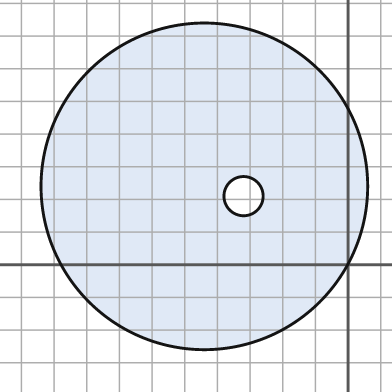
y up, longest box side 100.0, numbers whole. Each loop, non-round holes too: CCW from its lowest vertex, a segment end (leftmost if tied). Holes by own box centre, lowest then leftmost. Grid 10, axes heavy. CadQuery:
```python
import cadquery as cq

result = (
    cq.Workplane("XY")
    .moveTo(-44.0, 24.0)
    .circle(50.0)
    .moveTo(-32.0, 21.0)
    .circle(6.0)
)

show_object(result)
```